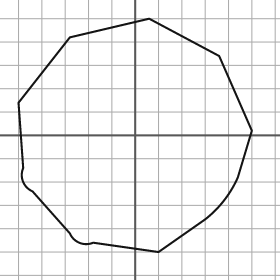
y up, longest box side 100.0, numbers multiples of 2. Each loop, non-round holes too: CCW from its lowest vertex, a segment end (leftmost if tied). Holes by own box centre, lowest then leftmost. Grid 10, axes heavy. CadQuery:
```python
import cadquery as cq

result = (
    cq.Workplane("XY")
    .moveTo(10.0, -50.0)
    .lineTo(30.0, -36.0)
    .threePointArc((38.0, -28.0), (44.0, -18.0))
    .lineTo(50.0, 2.0)
    .lineTo(36.0, 34.0)
    .lineTo(6.0, 50.0)
    .lineTo(-28.0, 42.0)
    .lineTo(-50.0, 14.0)
    .lineTo(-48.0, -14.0)
    .threePointArc((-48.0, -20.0), (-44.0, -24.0))
    .lineTo(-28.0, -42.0)
    .threePointArc((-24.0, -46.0), (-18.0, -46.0))
    .close()
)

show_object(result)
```